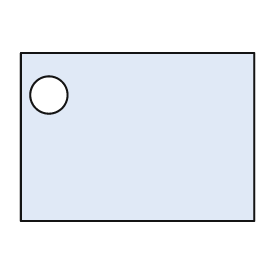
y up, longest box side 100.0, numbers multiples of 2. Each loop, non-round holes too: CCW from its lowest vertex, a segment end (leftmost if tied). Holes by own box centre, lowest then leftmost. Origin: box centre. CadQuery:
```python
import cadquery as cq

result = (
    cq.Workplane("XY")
    .moveTo(-50.0, -36.0)
    .lineTo(50.0, -36.0)
    .lineTo(50.0, 36.0)
    .lineTo(-50.0, 36.0)
    .close()
    .moveTo(-38.0, 18.0)
    .circle(8.0)
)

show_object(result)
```